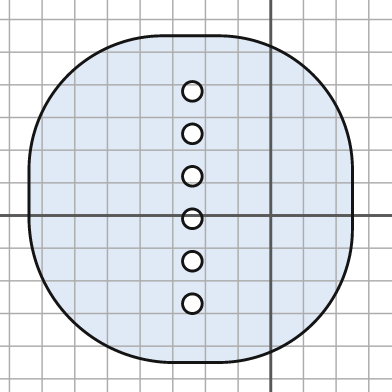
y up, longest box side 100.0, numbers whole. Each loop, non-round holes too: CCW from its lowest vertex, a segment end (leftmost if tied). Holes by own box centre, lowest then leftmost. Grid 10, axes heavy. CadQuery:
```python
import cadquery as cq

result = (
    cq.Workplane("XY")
    .moveTo(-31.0, -45.0)
    .lineTo(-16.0, -45.0)
    .threePointArc((13.0, -33.0), (25.0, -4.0))
    .lineTo(25.0, 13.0)
    .threePointArc((13.0, 43.0), (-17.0, 55.0))
    .lineTo(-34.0, 55.0)
    .threePointArc((-62.0, 43.0), (-74.0, 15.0))
    .lineTo(-74.0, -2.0)
    .threePointArc((-61.0, -32.0), (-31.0, -45.0))
    .close()
    .moveTo(-24.0, -27.0)
    .circle(3.0)
    .moveTo(-24.0, -14.0)
    .circle(3.0)
    .moveTo(-24.0, -1.0)
    .circle(3.0)
    .moveTo(-24.0, 12.0)
    .circle(3.0)
    .moveTo(-24.0, 25.0)
    .circle(3.0)
    .moveTo(-24.0, 38.0)
    .circle(3.0)
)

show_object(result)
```